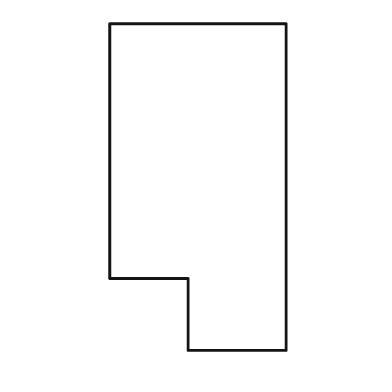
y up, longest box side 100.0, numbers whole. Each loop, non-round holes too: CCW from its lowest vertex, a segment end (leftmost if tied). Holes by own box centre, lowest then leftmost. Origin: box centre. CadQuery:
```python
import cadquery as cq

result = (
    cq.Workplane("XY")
    .moveTo(-3.0, -50.0)
    .lineTo(27.0, -50.0)
    .lineTo(27.0, 50.0)
    .lineTo(-27.0, 50.0)
    .lineTo(-27.0, -28.0)
    .lineTo(-3.0, -28.0)
    .close()
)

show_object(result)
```